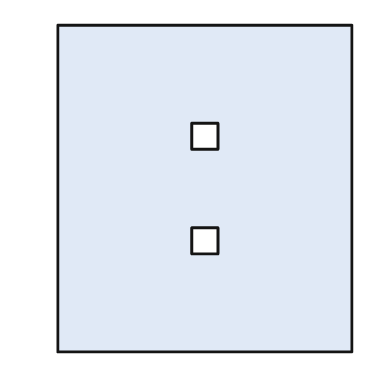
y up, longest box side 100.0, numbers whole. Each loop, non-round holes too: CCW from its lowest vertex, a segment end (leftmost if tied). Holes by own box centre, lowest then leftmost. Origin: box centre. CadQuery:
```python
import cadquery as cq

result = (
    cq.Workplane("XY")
    .moveTo(-45.0, -50.0)
    .lineTo(45.0, -50.0)
    .lineTo(45.0, 50.0)
    .lineTo(-45.0, 50.0)
    .close()
    .moveTo(-4.0, -20.0)
    .lineTo(4.0, -20.0)
    .lineTo(4.0, -12.0)
    .lineTo(-4.0, -12.0)
    .close()
    .moveTo(-4.0, 12.0)
    .lineTo(4.0, 12.0)
    .lineTo(4.0, 20.0)
    .lineTo(-4.0, 20.0)
    .close()
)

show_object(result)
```